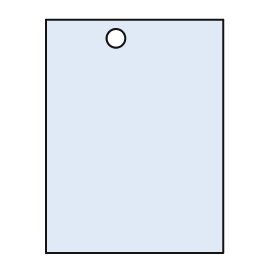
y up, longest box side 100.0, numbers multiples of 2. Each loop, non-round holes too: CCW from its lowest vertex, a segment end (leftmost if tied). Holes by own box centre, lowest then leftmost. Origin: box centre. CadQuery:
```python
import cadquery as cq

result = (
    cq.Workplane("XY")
    .moveTo(-38.0, -50.0)
    .lineTo(38.0, -50.0)
    .lineTo(38.0, 50.0)
    .lineTo(-38.0, 50.0)
    .close()
    .moveTo(-8.0, 42.0)
    .circle(4.0)
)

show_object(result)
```